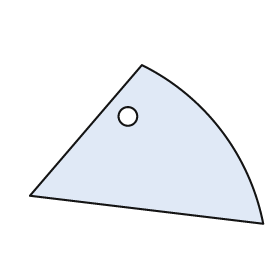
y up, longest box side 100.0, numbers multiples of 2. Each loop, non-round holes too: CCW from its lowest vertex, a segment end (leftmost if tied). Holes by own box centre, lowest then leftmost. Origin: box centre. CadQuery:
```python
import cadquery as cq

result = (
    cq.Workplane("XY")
    .moveTo(50.0, -34.0)
    .threePointArc((32.0, 6.0), (-2.0, 34.0))
    .lineTo(-50.0, -22.0)
    .close()
    .moveTo(-8.0, 12.0)
    .circle(4.0)
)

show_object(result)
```